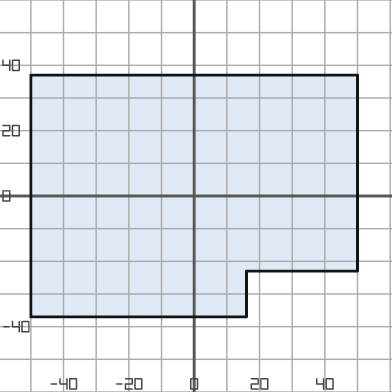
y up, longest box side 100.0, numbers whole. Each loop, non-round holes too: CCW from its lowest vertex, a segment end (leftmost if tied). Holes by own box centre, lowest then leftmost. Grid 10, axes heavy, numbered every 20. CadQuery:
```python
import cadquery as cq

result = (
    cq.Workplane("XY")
    .moveTo(-50.0, -37.0)
    .lineTo(16.0, -37.0)
    .lineTo(16.0, -23.0)
    .lineTo(50.0, -23.0)
    .lineTo(50.0, 37.0)
    .lineTo(-50.0, 37.0)
    .close()
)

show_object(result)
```